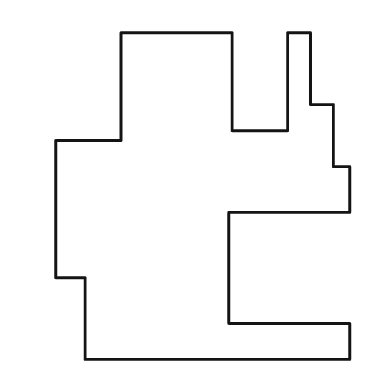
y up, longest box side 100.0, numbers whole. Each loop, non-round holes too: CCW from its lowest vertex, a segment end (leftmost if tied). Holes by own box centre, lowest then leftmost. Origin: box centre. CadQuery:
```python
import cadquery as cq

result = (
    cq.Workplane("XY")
    .moveTo(-36.0, -50.0)
    .lineTo(45.0, -50.0)
    .lineTo(45.0, -39.0)
    .lineTo(8.0, -39.0)
    .lineTo(8.0, -5.0)
    .lineTo(45.0, -5.0)
    .lineTo(45.0, 9.0)
    .lineTo(40.0, 9.0)
    .lineTo(40.0, 28.0)
    .lineTo(33.0, 28.0)
    .lineTo(33.0, 50.0)
    .lineTo(26.0, 50.0)
    .lineTo(26.0, 20.0)
    .lineTo(9.0, 20.0)
    .lineTo(9.0, 50.0)
    .lineTo(-25.0, 50.0)
    .lineTo(-25.0, 17.0)
    .lineTo(-45.0, 17.0)
    .lineTo(-45.0, -25.0)
    .lineTo(-36.0, -25.0)
    .close()
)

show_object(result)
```